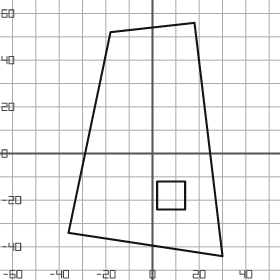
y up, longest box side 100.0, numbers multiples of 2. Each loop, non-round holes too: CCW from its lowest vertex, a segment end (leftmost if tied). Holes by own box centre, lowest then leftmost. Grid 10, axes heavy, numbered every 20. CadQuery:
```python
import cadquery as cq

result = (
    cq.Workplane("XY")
    .moveTo(30.0, -44.0)
    .lineTo(18.0, 56.0)
    .lineTo(-18.0, 52.0)
    .lineTo(-36.0, -34.0)
    .close()
    .moveTo(2.0, -24.0)
    .lineTo(14.0, -24.0)
    .lineTo(14.0, -12.0)
    .lineTo(2.0, -12.0)
    .close()
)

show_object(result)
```